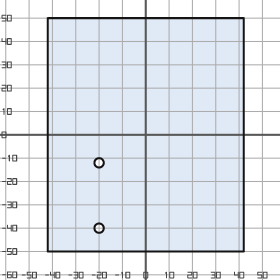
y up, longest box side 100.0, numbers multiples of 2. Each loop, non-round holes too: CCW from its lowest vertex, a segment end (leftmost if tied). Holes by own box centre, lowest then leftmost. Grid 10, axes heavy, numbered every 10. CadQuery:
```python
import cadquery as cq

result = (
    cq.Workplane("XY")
    .moveTo(-42.0, -50.0)
    .lineTo(42.0, -50.0)
    .lineTo(42.0, 50.0)
    .lineTo(-42.0, 50.0)
    .close()
    .moveTo(-20.0, -40.0)
    .circle(2.0)
    .moveTo(-20.0, -12.0)
    .circle(2.0)
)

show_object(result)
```